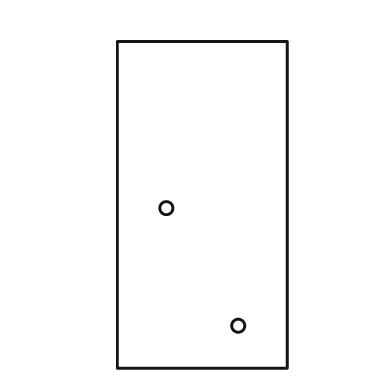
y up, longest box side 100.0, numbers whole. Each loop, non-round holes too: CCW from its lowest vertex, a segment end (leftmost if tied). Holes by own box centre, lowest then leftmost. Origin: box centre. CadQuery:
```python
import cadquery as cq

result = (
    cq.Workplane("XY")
    .moveTo(-26.0, -50.0)
    .lineTo(26.0, -50.0)
    .lineTo(26.0, 50.0)
    .lineTo(-26.0, 50.0)
    .close()
    .moveTo(11.0, -37.0)
    .circle(2.0)
    .moveTo(-11.0, -1.0)
    .circle(2.0)
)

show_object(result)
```